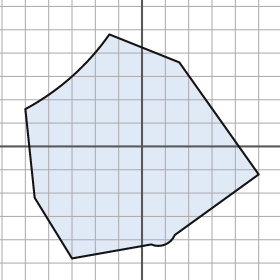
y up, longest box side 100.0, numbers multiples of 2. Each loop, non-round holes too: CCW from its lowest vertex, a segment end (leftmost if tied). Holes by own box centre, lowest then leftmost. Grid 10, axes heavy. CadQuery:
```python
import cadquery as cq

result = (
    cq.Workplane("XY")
    .moveTo(-30.0, -48.0)
    .lineTo(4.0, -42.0)
    .threePointArc((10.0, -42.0), (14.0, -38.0))
    .lineTo(50.0, -12.0)
    .lineTo(16.0, 36.0)
    .lineTo(-14.0, 48.0)
    .threePointArc((-30.0, 30.0), (-50.0, 16.0))
    .lineTo(-46.0, -22.0)
    .close()
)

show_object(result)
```